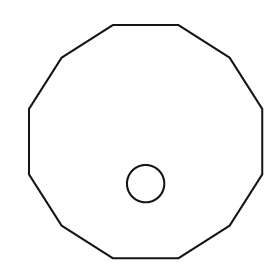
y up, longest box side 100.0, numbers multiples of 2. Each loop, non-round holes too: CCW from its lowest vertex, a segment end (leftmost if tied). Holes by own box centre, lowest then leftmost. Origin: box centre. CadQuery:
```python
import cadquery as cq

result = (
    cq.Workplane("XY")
    .moveTo(-14.0, -50.0)
    .lineTo(14.0, -50.0)
    .lineTo(36.0, -36.0)
    .lineTo(50.0, -14.0)
    .lineTo(50.0, 14.0)
    .lineTo(36.0, 36.0)
    .lineTo(14.0, 50.0)
    .lineTo(-14.0, 50.0)
    .lineTo(-36.0, 36.0)
    .lineTo(-50.0, 14.0)
    .lineTo(-50.0, -14.0)
    .lineTo(-36.0, -36.0)
    .close()
    .moveTo(0.0, -18.0)
    .circle(8.0)
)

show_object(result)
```